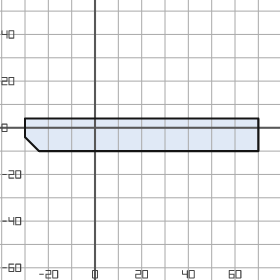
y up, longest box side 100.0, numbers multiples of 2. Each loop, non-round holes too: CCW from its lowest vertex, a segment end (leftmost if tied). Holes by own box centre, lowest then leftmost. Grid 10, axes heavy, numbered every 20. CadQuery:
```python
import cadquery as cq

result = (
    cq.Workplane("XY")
    .moveTo(-24.0, -10.0)
    .lineTo(70.0, -10.0)
    .lineTo(70.0, 4.0)
    .lineTo(-30.0, 4.0)
    .lineTo(-30.0, -4.0)
    .close()
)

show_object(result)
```